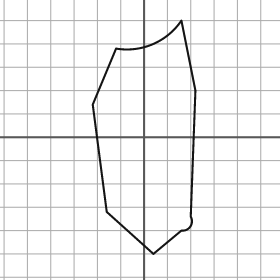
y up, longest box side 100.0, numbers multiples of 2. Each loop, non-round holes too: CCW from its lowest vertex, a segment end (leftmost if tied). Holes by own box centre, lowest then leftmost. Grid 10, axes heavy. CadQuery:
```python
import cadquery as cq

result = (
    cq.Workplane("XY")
    .moveTo(4.0, -50.0)
    .lineTo(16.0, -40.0)
    .threePointArc((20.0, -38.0), (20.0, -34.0))
    .lineTo(22.0, 20.0)
    .lineTo(16.0, 50.0)
    .threePointArc((4.0, 40.0), (-12.0, 38.0))
    .lineTo(-22.0, 14.0)
    .lineTo(-16.0, -32.0)
    .close()
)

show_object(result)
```